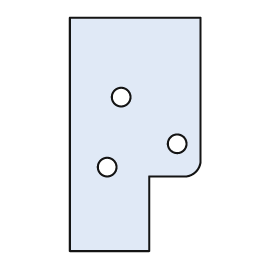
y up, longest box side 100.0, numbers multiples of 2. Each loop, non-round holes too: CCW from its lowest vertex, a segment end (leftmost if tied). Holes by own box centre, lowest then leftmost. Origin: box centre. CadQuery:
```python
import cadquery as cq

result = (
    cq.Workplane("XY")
    .moveTo(-28.0, -50.0)
    .lineTo(6.0, -50.0)
    .lineTo(6.0, -18.0)
    .lineTo(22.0, -18.0)
    .threePointArc((26.0, -16.0), (28.0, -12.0))
    .lineTo(28.0, 50.0)
    .lineTo(-28.0, 50.0)
    .close()
    .moveTo(-12.0, -14.0)
    .circle(4.0)
    .moveTo(18.0, -4.0)
    .circle(4.0)
    .moveTo(-6.0, 16.0)
    .circle(4.0)
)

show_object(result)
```